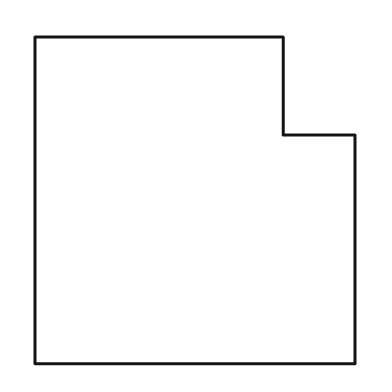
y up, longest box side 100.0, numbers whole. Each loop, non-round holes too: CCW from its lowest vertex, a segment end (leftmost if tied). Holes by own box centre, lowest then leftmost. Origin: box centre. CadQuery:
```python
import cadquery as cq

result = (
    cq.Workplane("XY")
    .moveTo(-49.0, -50.0)
    .lineTo(49.0, -50.0)
    .lineTo(49.0, 20.0)
    .lineTo(27.0, 20.0)
    .lineTo(27.0, 50.0)
    .lineTo(-49.0, 50.0)
    .close()
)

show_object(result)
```